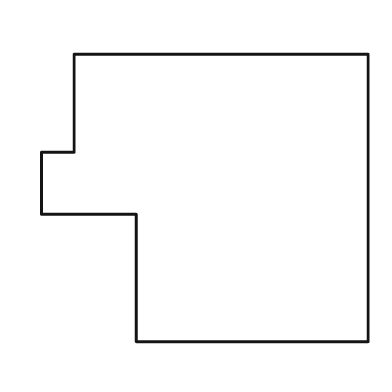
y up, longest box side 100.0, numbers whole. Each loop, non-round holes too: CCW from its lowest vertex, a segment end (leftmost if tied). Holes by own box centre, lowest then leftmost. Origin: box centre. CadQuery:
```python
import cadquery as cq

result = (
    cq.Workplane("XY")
    .moveTo(-21.0, -44.0)
    .lineTo(50.0, -44.0)
    .lineTo(50.0, 44.0)
    .lineTo(-40.0, 44.0)
    .lineTo(-40.0, 14.0)
    .lineTo(-50.0, 14.0)
    .lineTo(-50.0, -5.0)
    .lineTo(-21.0, -5.0)
    .close()
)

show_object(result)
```